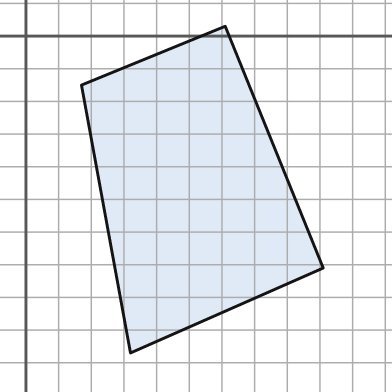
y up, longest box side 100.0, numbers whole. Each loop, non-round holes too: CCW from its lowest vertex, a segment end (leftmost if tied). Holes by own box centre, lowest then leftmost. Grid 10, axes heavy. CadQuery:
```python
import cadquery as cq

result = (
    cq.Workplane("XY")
    .moveTo(32.0, -97.0)
    .lineTo(91.0, -71.0)
    .lineTo(61.0, 3.0)
    .lineTo(17.0, -15.0)
    .close()
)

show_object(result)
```